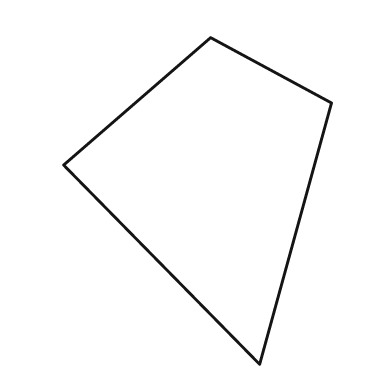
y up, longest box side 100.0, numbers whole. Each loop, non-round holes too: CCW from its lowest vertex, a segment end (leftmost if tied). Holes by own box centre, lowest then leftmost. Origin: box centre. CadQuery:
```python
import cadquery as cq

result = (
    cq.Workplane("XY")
    .moveTo(19.0, -50.0)
    .lineTo(41.0, 30.0)
    .lineTo(4.0, 50.0)
    .lineTo(-41.0, 11.0)
    .close()
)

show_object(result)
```